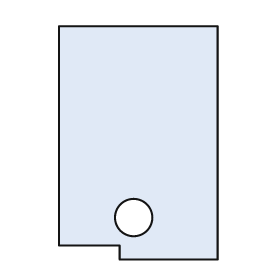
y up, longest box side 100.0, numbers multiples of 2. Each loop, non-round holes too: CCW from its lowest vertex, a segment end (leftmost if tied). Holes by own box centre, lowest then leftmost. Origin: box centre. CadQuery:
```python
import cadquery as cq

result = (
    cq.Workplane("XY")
    .moveTo(-8.0, -50.0)
    .lineTo(34.0, -50.0)
    .lineTo(34.0, 50.0)
    .lineTo(-34.0, 50.0)
    .lineTo(-34.0, -44.0)
    .lineTo(-8.0, -44.0)
    .close()
    .moveTo(-2.0, -32.0)
    .circle(8.0)
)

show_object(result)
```